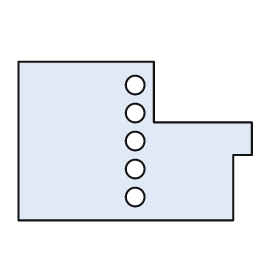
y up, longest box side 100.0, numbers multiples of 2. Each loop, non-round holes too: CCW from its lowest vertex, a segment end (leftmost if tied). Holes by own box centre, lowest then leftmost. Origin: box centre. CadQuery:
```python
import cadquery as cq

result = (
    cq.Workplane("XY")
    .moveTo(-50.0, -34.0)
    .lineTo(42.0, -34.0)
    .lineTo(42.0, -6.0)
    .lineTo(50.0, -6.0)
    .lineTo(50.0, 8.0)
    .lineTo(8.0, 8.0)
    .lineTo(8.0, 34.0)
    .lineTo(-50.0, 34.0)
    .close()
    .moveTo(0.0, -24.0)
    .circle(4.0)
    .moveTo(0.0, -12.0)
    .circle(4.0)
    .moveTo(0.0, 0.0)
    .circle(4.0)
    .moveTo(0.0, 12.0)
    .circle(4.0)
    .moveTo(0.0, 24.0)
    .circle(4.0)
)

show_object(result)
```